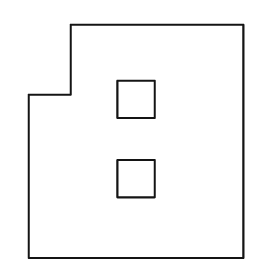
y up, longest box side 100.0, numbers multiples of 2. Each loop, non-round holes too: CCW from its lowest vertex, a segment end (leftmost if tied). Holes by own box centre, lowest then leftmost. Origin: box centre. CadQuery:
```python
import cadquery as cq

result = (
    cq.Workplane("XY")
    .moveTo(-46.0, -50.0)
    .lineTo(46.0, -50.0)
    .lineTo(46.0, 50.0)
    .lineTo(-28.0, 50.0)
    .lineTo(-28.0, 20.0)
    .lineTo(-46.0, 20.0)
    .close()
    .moveTo(-8.0, -24.0)
    .lineTo(8.0, -24.0)
    .lineTo(8.0, -8.0)
    .lineTo(-8.0, -8.0)
    .close()
    .moveTo(-8.0, 10.0)
    .lineTo(8.0, 10.0)
    .lineTo(8.0, 26.0)
    .lineTo(-8.0, 26.0)
    .close()
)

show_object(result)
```